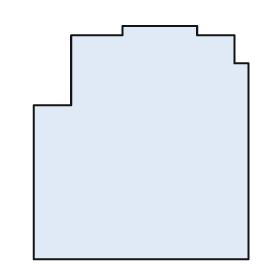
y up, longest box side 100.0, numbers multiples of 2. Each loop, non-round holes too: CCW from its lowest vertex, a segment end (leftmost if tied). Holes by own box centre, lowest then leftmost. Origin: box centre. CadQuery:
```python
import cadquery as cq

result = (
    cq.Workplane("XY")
    .moveTo(-46.0, -50.0)
    .lineTo(46.0, -50.0)
    .lineTo(46.0, 34.0)
    .lineTo(40.0, 34.0)
    .lineTo(40.0, 46.0)
    .lineTo(24.0, 46.0)
    .lineTo(24.0, 50.0)
    .lineTo(-8.0, 50.0)
    .lineTo(-8.0, 46.0)
    .lineTo(-30.0, 46.0)
    .lineTo(-30.0, 16.0)
    .lineTo(-46.0, 16.0)
    .close()
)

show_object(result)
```